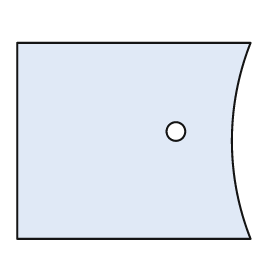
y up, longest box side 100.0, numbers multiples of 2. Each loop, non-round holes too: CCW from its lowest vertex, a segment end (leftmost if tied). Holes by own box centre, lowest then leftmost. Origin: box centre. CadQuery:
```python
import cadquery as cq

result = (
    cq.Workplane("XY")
    .moveTo(-50.0, -42.0)
    .lineTo(50.0, -42.0)
    .threePointArc((42.0, 0.0), (50.0, 42.0))
    .lineTo(-50.0, 42.0)
    .close()
    .moveTo(18.0, 4.0)
    .circle(4.0)
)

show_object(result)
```